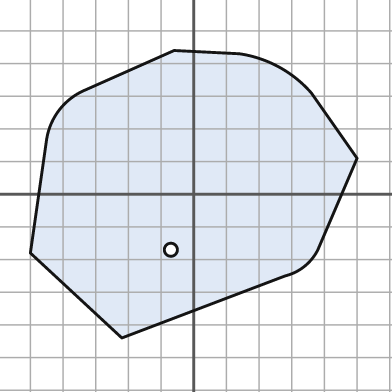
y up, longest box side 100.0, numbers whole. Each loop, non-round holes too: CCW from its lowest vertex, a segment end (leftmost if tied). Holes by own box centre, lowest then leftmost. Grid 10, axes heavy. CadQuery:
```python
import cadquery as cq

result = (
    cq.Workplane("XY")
    .moveTo(-22.0, -44.0)
    .lineTo(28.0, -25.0)
    .threePointArc((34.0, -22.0), (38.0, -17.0))
    .lineTo(50.0, 11.0)
    .lineTo(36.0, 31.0)
    .threePointArc((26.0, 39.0), (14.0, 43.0))
    .lineTo(-6.0, 44.0)
    .lineTo(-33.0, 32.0)
    .threePointArc((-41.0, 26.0), (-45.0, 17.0))
    .lineTo(-50.0, -18.0)
    .close()
    .moveTo(-7.0, -17.0)
    .circle(2.0)
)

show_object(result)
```